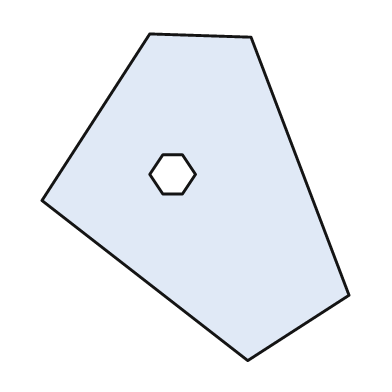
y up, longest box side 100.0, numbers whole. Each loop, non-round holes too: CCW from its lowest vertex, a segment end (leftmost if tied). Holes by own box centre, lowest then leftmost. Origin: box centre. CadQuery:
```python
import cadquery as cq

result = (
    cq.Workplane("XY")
    .moveTo(16.0, -50.0)
    .lineTo(47.0, -30.0)
    .lineTo(17.0, 49.0)
    .lineTo(-14.0, 50.0)
    .lineTo(-47.0, -1.0)
    .close()
    .moveTo(-10.0, 1.0)
    .lineTo(-4.0, 1.0)
    .lineTo(0.0, 7.0)
    .lineTo(-4.0, 13.0)
    .lineTo(-10.0, 13.0)
    .lineTo(-14.0, 7.0)
    .close()
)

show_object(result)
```